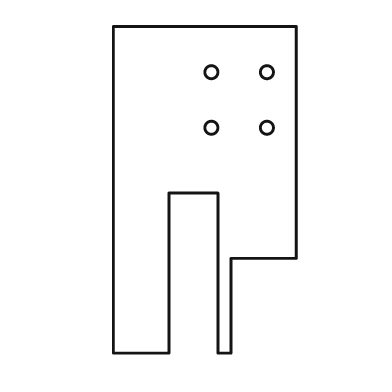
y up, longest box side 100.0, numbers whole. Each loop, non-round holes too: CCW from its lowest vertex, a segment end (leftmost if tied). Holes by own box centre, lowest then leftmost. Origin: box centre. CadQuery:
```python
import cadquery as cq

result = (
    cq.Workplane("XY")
    .moveTo(-28.0, -50.0)
    .lineTo(-11.0, -50.0)
    .lineTo(-11.0, -1.0)
    .lineTo(4.0, -1.0)
    .lineTo(4.0, -50.0)
    .lineTo(8.0, -50.0)
    .lineTo(8.0, -21.0)
    .lineTo(28.0, -21.0)
    .lineTo(28.0, 50.0)
    .lineTo(-28.0, 50.0)
    .close()
    .moveTo(2.0, 19.0)
    .circle(2.0)
    .moveTo(19.0, 19.0)
    .circle(2.0)
    .moveTo(2.0, 36.0)
    .circle(2.0)
    .moveTo(19.0, 36.0)
    .circle(2.0)
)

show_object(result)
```